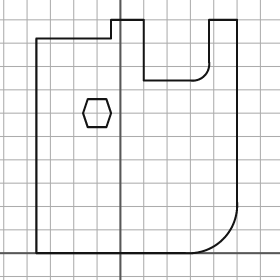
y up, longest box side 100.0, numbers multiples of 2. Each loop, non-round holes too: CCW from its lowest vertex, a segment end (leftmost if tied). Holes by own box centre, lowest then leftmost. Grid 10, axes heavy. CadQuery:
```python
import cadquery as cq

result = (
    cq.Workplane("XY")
    .moveTo(-36.0, 0.0)
    .lineTo(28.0, 0.0)
    .threePointArc((44.0, 6.0), (50.0, 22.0))
    .lineTo(50.0, 100.0)
    .lineTo(38.0, 100.0)
    .lineTo(38.0, 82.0)
    .threePointArc((36.0, 76.0), (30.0, 74.0))
    .lineTo(10.0, 74.0)
    .lineTo(10.0, 100.0)
    .lineTo(-4.0, 100.0)
    .lineTo(-4.0, 92.0)
    .lineTo(-36.0, 92.0)
    .close()
    .moveTo(-14.0, 54.0)
    .lineTo(-6.0, 54.0)
    .lineTo(-4.0, 60.0)
    .lineTo(-6.0, 66.0)
    .lineTo(-14.0, 66.0)
    .lineTo(-16.0, 60.0)
    .close()
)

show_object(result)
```